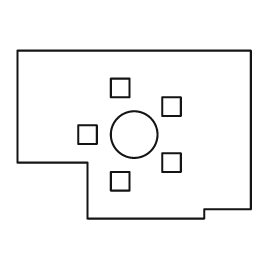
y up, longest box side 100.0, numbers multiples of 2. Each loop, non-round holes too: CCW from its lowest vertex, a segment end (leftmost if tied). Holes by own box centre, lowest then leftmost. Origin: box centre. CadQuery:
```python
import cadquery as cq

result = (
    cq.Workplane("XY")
    .moveTo(-20.0, -36.0)
    .lineTo(30.0, -36.0)
    .lineTo(30.0, -32.0)
    .lineTo(50.0, -32.0)
    .lineTo(50.0, 36.0)
    .lineTo(-50.0, 36.0)
    .lineTo(-50.0, -12.0)
    .lineTo(-20.0, -12.0)
    .close()
    .moveTo(-10.0, -24.0)
    .lineTo(-2.0, -24.0)
    .lineTo(-2.0, -16.0)
    .lineTo(-10.0, -16.0)
    .close()
    .moveTo(12.0, -16.0)
    .lineTo(20.0, -16.0)
    .lineTo(20.0, -8.0)
    .lineTo(12.0, -8.0)
    .close()
    .moveTo(-24.0, -4.0)
    .lineTo(-16.0, -4.0)
    .lineTo(-16.0, 4.0)
    .lineTo(-24.0, 4.0)
    .close()
    .moveTo(0.0, 0.0)
    .circle(10.0)
    .moveTo(12.0, 8.0)
    .lineTo(20.0, 8.0)
    .lineTo(20.0, 16.0)
    .lineTo(12.0, 16.0)
    .close()
    .moveTo(-10.0, 16.0)
    .lineTo(-2.0, 16.0)
    .lineTo(-2.0, 24.0)
    .lineTo(-10.0, 24.0)
    .close()
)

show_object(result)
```